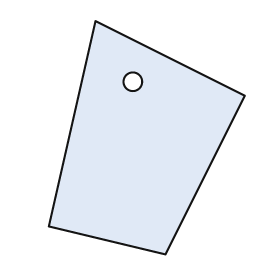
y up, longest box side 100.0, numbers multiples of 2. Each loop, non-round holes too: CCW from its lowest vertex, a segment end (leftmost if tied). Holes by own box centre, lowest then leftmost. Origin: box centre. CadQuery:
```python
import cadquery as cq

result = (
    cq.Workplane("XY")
    .moveTo(8.0, -50.0)
    .lineTo(42.0, 18.0)
    .lineTo(-22.0, 50.0)
    .lineTo(-42.0, -38.0)
    .close()
    .moveTo(-6.0, 24.0)
    .circle(4.0)
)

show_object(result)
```